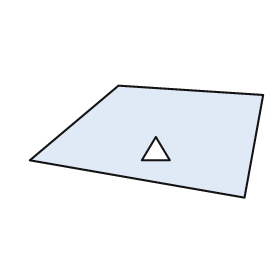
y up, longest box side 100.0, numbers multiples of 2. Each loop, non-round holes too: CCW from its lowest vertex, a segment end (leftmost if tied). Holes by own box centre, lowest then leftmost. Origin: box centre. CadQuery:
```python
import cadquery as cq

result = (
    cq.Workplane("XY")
    .moveTo(42.0, -24.0)
    .lineTo(50.0, 20.0)
    .lineTo(-12.0, 24.0)
    .lineTo(-50.0, -8.0)
    .close()
    .moveTo(-2.0, -8.0)
    .lineTo(10.0, -8.0)
    .lineTo(4.0, 2.0)
    .close()
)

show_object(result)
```